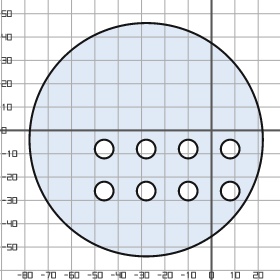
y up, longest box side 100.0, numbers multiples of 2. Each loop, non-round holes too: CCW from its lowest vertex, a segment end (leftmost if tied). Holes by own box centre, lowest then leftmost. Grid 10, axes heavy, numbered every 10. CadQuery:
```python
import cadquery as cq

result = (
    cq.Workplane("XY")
    .moveTo(-28.0, -4.0)
    .circle(50.0)
    .moveTo(-46.0, -26.0)
    .circle(4.0)
    .moveTo(-28.0, -26.0)
    .circle(4.0)
    .moveTo(-10.0, -26.0)
    .circle(4.0)
    .moveTo(8.0, -26.0)
    .circle(4.0)
    .moveTo(-46.0, -8.0)
    .circle(4.0)
    .moveTo(-28.0, -8.0)
    .circle(4.0)
    .moveTo(-10.0, -8.0)
    .circle(4.0)
    .moveTo(8.0, -8.0)
    .circle(4.0)
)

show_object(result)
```